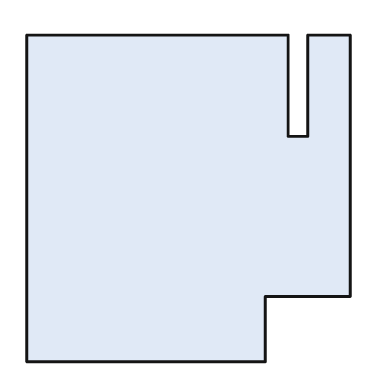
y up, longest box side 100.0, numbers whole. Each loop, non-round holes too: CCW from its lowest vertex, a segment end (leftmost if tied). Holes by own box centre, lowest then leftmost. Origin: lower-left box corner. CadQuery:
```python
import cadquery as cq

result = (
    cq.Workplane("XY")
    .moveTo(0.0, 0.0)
    .lineTo(73.0, 0.0)
    .lineTo(73.0, 20.0)
    .lineTo(99.0, 20.0)
    .lineTo(99.0, 100.0)
    .lineTo(86.0, 100.0)
    .lineTo(86.0, 69.0)
    .lineTo(80.0, 69.0)
    .lineTo(80.0, 100.0)
    .lineTo(0.0, 100.0)
    .close()
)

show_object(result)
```